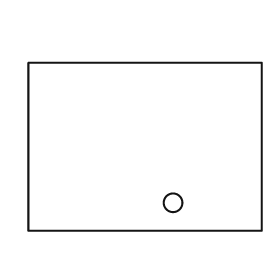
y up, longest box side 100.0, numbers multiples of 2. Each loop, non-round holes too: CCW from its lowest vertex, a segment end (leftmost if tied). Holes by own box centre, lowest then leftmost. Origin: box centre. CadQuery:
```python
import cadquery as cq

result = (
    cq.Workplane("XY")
    .moveTo(-50.0, -36.0)
    .lineTo(50.0, -36.0)
    .lineTo(50.0, 36.0)
    .lineTo(-50.0, 36.0)
    .close()
    .moveTo(12.0, -24.0)
    .circle(4.0)
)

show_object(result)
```